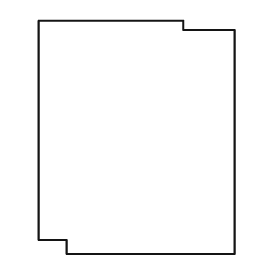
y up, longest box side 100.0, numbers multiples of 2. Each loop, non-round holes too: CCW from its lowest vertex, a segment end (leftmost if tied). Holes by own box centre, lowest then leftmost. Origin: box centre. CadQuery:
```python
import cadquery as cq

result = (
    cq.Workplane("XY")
    .moveTo(-30.0, -50.0)
    .lineTo(42.0, -50.0)
    .lineTo(42.0, 46.0)
    .lineTo(20.0, 46.0)
    .lineTo(20.0, 50.0)
    .lineTo(-42.0, 50.0)
    .lineTo(-42.0, -44.0)
    .lineTo(-30.0, -44.0)
    .close()
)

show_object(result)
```